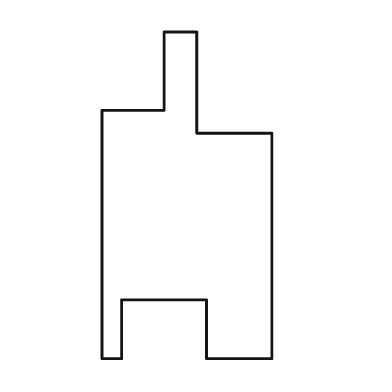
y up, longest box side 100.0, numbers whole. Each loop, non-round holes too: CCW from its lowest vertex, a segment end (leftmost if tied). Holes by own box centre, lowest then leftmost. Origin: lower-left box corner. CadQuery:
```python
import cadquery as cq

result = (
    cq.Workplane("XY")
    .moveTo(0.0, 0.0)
    .lineTo(6.0, 0.0)
    .lineTo(6.0, 18.0)
    .lineTo(32.0, 18.0)
    .lineTo(32.0, 0.0)
    .lineTo(52.0, 0.0)
    .lineTo(52.0, 69.0)
    .lineTo(29.0, 69.0)
    .lineTo(29.0, 100.0)
    .lineTo(19.0, 100.0)
    .lineTo(19.0, 76.0)
    .lineTo(0.0, 76.0)
    .close()
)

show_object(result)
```